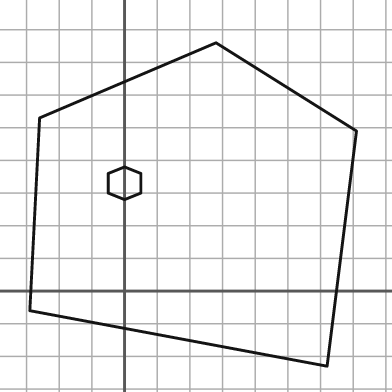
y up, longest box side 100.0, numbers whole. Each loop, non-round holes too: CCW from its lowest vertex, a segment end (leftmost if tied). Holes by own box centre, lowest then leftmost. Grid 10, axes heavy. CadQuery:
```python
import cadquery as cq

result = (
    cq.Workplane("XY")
    .moveTo(62.0, -23.0)
    .lineTo(71.0, 49.0)
    .lineTo(28.0, 76.0)
    .lineTo(-26.0, 53.0)
    .lineTo(-29.0, -6.0)
    .close()
    .moveTo(0.0, 28.0)
    .lineTo(5.0, 30.0)
    .lineTo(5.0, 36.0)
    .lineTo(0.0, 38.0)
    .lineTo(-5.0, 36.0)
    .lineTo(-5.0, 30.0)
    .close()
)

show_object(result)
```